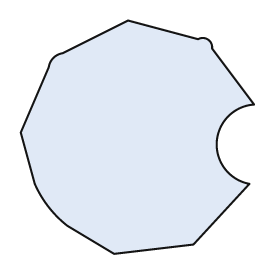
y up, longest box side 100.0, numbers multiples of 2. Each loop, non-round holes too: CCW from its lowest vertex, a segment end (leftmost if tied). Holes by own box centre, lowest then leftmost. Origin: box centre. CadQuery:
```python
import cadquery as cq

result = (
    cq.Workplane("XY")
    .moveTo(-10.0, -50.0)
    .lineTo(24.0, -46.0)
    .lineTo(48.0, -20.0)
    .threePointArc((34.0, -2.0), (50.0, 14.0))
    .lineTo(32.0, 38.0)
    .threePointArc((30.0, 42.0), (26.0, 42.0))
    .lineTo(-4.0, 50.0)
    .lineTo(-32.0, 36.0)
    .threePointArc((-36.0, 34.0), (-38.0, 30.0))
    .lineTo(-50.0, 2.0)
    .lineTo(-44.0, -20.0)
    .threePointArc((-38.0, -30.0), (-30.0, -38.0))
    .close()
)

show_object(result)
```